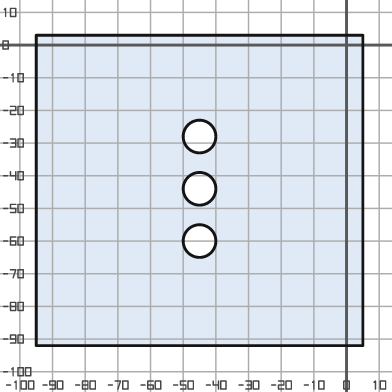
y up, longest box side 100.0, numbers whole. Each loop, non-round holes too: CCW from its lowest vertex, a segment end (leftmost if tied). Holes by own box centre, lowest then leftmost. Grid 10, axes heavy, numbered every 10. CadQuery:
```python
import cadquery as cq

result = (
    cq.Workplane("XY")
    .moveTo(-95.0, -92.0)
    .lineTo(5.0, -92.0)
    .lineTo(5.0, 3.0)
    .lineTo(-95.0, 3.0)
    .close()
    .moveTo(-45.0, -60.0)
    .circle(5.0)
    .moveTo(-45.0, -44.0)
    .circle(5.0)
    .moveTo(-45.0, -28.0)
    .circle(5.0)
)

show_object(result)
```